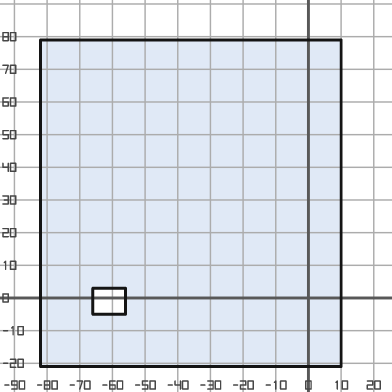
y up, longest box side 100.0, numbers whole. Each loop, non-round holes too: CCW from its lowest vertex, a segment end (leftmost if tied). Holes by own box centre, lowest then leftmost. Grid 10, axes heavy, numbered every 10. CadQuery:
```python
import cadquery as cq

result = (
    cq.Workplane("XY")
    .moveTo(-82.0, -21.0)
    .lineTo(10.0, -21.0)
    .lineTo(10.0, 79.0)
    .lineTo(-82.0, 79.0)
    .close()
    .moveTo(-66.0, -5.0)
    .lineTo(-56.0, -5.0)
    .lineTo(-56.0, 3.0)
    .lineTo(-66.0, 3.0)
    .close()
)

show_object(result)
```